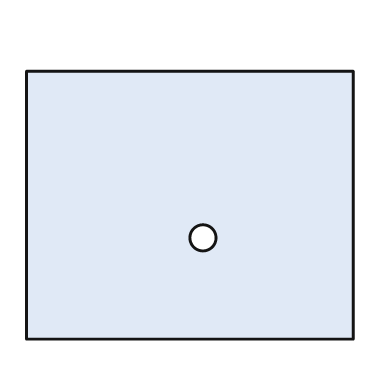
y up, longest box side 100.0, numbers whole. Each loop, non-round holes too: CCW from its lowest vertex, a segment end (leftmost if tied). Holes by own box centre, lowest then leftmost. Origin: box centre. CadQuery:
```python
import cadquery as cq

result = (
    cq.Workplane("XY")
    .moveTo(-50.0, -41.0)
    .lineTo(50.0, -41.0)
    .lineTo(50.0, 41.0)
    .lineTo(-50.0, 41.0)
    .close()
    .moveTo(4.0, -10.0)
    .circle(4.0)
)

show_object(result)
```